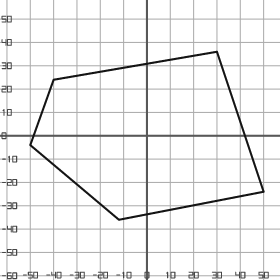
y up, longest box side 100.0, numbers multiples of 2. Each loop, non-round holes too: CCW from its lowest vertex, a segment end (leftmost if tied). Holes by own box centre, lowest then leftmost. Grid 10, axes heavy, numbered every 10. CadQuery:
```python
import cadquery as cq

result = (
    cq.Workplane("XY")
    .moveTo(-12.0, -36.0)
    .lineTo(50.0, -24.0)
    .lineTo(30.0, 36.0)
    .lineTo(-40.0, 24.0)
    .lineTo(-50.0, -4.0)
    .close()
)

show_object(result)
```